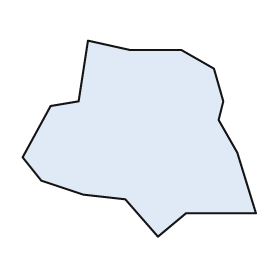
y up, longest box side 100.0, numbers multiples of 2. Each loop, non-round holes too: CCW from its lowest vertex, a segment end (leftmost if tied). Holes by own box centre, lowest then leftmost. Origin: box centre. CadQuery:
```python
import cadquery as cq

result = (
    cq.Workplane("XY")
    .moveTo(8.0, -42.0)
    .lineTo(20.0, -32.0)
    .lineTo(50.0, -32.0)
    .lineTo(42.0, -6.0)
    .lineTo(34.0, 8.0)
    .lineTo(36.0, 16.0)
    .lineTo(32.0, 30.0)
    .lineTo(18.0, 38.0)
    .lineTo(-4.0, 38.0)
    .lineTo(-22.0, 42.0)
    .lineTo(-26.0, 16.0)
    .lineTo(-38.0, 14.0)
    .lineTo(-50.0, -8.0)
    .lineTo(-42.0, -18.0)
    .lineTo(-24.0, -24.0)
    .lineTo(-6.0, -26.0)
    .close()
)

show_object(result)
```